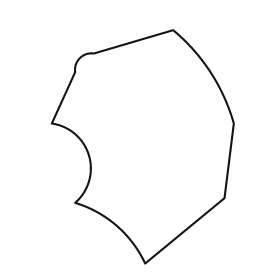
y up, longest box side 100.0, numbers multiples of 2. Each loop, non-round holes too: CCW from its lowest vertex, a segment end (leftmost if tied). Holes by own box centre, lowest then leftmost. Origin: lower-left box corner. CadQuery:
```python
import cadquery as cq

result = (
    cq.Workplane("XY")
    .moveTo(40.0, 0.0)
    .lineTo(74.0, 28.0)
    .lineTo(78.0, 60.0)
    .threePointArc((68.0, 82.0), (52.0, 100.0))
    .lineTo(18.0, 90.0)
    .threePointArc((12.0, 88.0), (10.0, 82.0))
    .lineTo(0.0, 60.0)
    .threePointArc((16.0, 46.0), (10.0, 26.0))
    .threePointArc((28.0, 16.0), (40.0, 0.0))
    .close()
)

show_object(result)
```